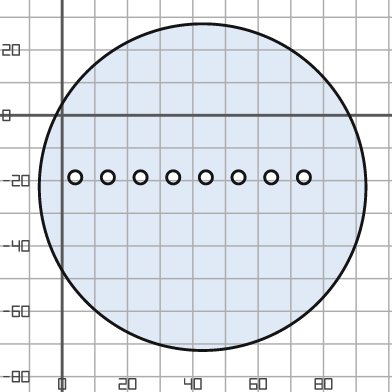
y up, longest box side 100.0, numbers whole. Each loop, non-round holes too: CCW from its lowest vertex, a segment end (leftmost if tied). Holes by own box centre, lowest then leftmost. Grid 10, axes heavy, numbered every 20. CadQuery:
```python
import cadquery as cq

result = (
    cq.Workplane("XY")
    .moveTo(43.0, -22.0)
    .circle(50.0)
    .moveTo(4.0, -19.0)
    .circle(2.0)
    .moveTo(14.0, -19.0)
    .circle(2.0)
    .moveTo(24.0, -19.0)
    .circle(2.0)
    .moveTo(34.0, -19.0)
    .circle(2.0)
    .moveTo(44.0, -19.0)
    .circle(2.0)
    .moveTo(54.0, -19.0)
    .circle(2.0)
    .moveTo(64.0, -19.0)
    .circle(2.0)
    .moveTo(74.0, -19.0)
    .circle(2.0)
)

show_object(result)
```